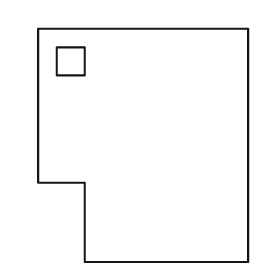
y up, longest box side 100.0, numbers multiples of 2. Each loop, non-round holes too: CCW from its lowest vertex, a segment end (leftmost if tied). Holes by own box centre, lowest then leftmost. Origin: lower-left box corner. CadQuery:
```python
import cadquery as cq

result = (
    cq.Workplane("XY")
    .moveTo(20.0, 0.0)
    .lineTo(90.0, 0.0)
    .lineTo(90.0, 100.0)
    .lineTo(0.0, 100.0)
    .lineTo(0.0, 34.0)
    .lineTo(20.0, 34.0)
    .close()
    .moveTo(8.0, 80.0)
    .lineTo(20.0, 80.0)
    .lineTo(20.0, 92.0)
    .lineTo(8.0, 92.0)
    .close()
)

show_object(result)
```